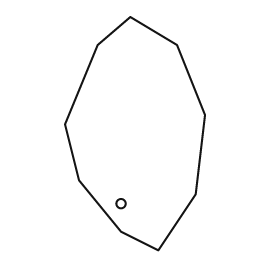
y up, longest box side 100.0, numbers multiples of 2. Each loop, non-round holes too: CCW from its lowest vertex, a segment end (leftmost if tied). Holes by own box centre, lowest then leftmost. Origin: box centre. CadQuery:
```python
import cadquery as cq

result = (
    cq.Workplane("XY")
    .moveTo(10.0, -50.0)
    .lineTo(26.0, -26.0)
    .lineTo(30.0, 8.0)
    .lineTo(18.0, 38.0)
    .lineTo(-2.0, 50.0)
    .lineTo(-16.0, 38.0)
    .lineTo(-30.0, 4.0)
    .lineTo(-24.0, -20.0)
    .lineTo(-6.0, -42.0)
    .close()
    .moveTo(-6.0, -30.0)
    .circle(2.0)
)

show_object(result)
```